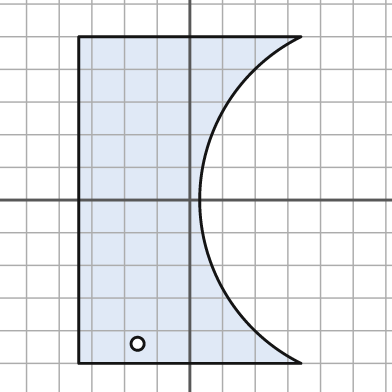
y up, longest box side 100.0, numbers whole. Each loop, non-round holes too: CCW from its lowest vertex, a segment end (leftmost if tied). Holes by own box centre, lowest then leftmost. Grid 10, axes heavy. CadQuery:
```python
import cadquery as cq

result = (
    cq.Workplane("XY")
    .moveTo(-34.0, -50.0)
    .lineTo(34.0, -50.0)
    .threePointArc((3.0, 0.0), (34.0, 50.0))
    .lineTo(-34.0, 50.0)
    .close()
    .moveTo(-16.0, -44.0)
    .circle(2.0)
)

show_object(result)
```